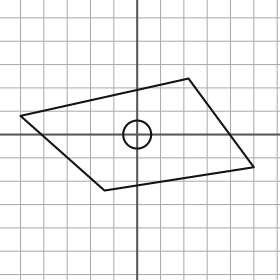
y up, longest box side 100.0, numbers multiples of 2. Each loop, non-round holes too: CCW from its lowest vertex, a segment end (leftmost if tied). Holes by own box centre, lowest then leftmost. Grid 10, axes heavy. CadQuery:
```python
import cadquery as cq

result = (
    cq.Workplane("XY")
    .moveTo(-14.0, -24.0)
    .lineTo(50.0, -14.0)
    .lineTo(22.0, 24.0)
    .lineTo(-50.0, 8.0)
    .close()
    .moveTo(0.0, 0.0)
    .circle(6.0)
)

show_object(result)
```